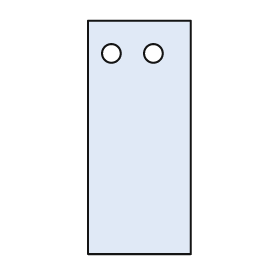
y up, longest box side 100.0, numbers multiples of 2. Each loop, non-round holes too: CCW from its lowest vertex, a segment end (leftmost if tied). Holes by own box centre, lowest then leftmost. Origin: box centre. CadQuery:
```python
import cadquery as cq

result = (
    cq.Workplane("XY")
    .moveTo(-22.0, -50.0)
    .lineTo(22.0, -50.0)
    .lineTo(22.0, 50.0)
    .lineTo(-22.0, 50.0)
    .close()
    .moveTo(-12.0, 36.0)
    .circle(4.0)
    .moveTo(6.0, 36.0)
    .circle(4.0)
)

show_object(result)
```